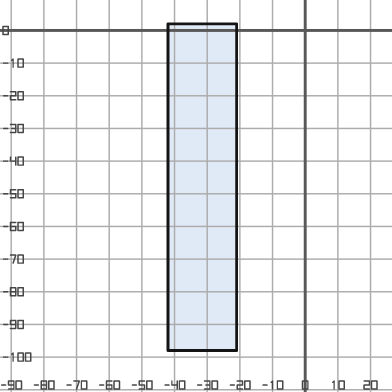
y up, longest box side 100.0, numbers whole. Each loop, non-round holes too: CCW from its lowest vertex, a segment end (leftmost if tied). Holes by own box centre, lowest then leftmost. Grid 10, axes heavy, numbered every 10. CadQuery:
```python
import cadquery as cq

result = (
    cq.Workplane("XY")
    .moveTo(-42.0, -98.0)
    .lineTo(-21.0, -98.0)
    .lineTo(-21.0, 2.0)
    .lineTo(-42.0, 2.0)
    .close()
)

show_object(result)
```